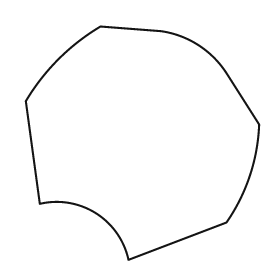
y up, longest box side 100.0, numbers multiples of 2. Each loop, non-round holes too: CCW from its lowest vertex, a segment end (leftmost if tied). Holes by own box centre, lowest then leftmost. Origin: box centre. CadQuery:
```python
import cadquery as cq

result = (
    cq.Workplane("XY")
    .moveTo(-6.0, -50.0)
    .lineTo(36.0, -34.0)
    .threePointArc((46.0, -14.0), (50.0, 8.0))
    .lineTo(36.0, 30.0)
    .threePointArc((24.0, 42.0), (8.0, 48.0))
    .lineTo(-18.0, 50.0)
    .threePointArc((-36.0, 36.0), (-50.0, 18.0))
    .lineTo(-44.0, -26.0)
    .threePointArc((-20.0, -30.0), (-6.0, -50.0))
    .close()
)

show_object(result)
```